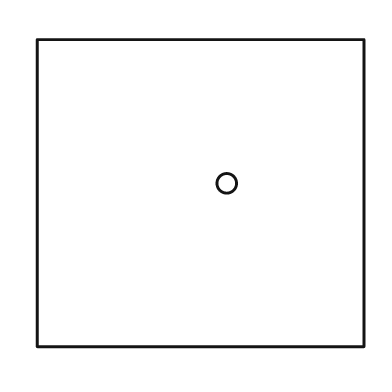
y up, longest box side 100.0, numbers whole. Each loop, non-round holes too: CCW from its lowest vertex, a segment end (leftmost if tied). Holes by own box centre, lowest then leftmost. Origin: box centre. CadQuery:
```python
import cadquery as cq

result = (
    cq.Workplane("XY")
    .moveTo(-50.0, -47.0)
    .lineTo(50.0, -47.0)
    .lineTo(50.0, 47.0)
    .lineTo(-50.0, 47.0)
    .close()
    .moveTo(8.0, 3.0)
    .circle(3.0)
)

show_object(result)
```